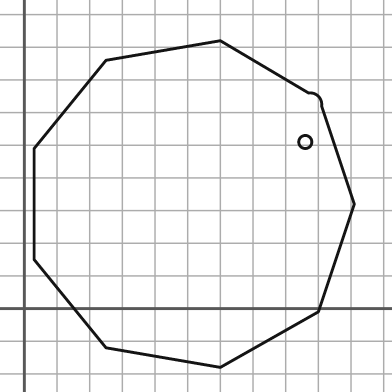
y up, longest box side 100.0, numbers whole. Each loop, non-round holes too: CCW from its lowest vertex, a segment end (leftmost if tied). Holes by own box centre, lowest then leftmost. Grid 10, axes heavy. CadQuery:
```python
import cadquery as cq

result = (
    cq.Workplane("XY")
    .moveTo(60.0, -18.0)
    .lineTo(90.0, -1.0)
    .lineTo(101.0, 32.0)
    .lineTo(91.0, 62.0)
    .threePointArc((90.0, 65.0), (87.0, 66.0))
    .lineTo(60.0, 82.0)
    .lineTo(25.0, 76.0)
    .lineTo(3.0, 49.0)
    .lineTo(3.0, 15.0)
    .lineTo(25.0, -12.0)
    .close()
    .moveTo(86.0, 51.0)
    .circle(2.0)
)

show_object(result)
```